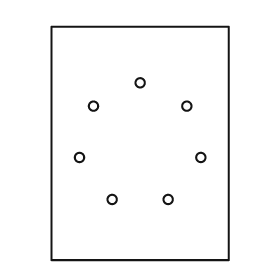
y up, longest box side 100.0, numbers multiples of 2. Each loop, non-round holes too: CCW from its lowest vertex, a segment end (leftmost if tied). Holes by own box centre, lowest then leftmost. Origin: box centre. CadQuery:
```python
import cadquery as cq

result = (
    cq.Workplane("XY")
    .moveTo(-38.0, -50.0)
    .lineTo(38.0, -50.0)
    .lineTo(38.0, 50.0)
    .lineTo(-38.0, 50.0)
    .close()
    .moveTo(-12.0, -24.0)
    .circle(2.0)
    .moveTo(12.0, -24.0)
    .circle(2.0)
    .moveTo(-26.0, -6.0)
    .circle(2.0)
    .moveTo(26.0, -6.0)
    .circle(2.0)
    .moveTo(-20.0, 16.0)
    .circle(2.0)
    .moveTo(20.0, 16.0)
    .circle(2.0)
    .moveTo(0.0, 26.0)
    .circle(2.0)
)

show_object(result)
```